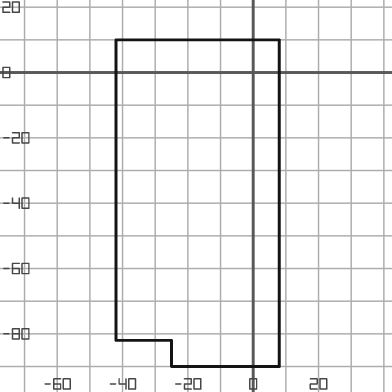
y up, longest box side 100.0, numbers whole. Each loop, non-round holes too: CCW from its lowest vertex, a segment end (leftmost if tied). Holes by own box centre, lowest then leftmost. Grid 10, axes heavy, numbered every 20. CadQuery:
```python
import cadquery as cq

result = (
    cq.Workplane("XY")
    .moveTo(-25.0, -90.0)
    .lineTo(8.0, -90.0)
    .lineTo(8.0, 10.0)
    .lineTo(-42.0, 10.0)
    .lineTo(-42.0, -82.0)
    .lineTo(-25.0, -82.0)
    .close()
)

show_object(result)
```